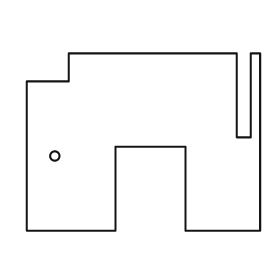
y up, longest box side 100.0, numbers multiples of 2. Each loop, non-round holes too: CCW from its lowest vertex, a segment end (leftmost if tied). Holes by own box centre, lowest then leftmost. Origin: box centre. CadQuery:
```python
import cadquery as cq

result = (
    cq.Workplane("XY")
    .moveTo(-50.0, -38.0)
    .lineTo(-12.0, -38.0)
    .lineTo(-12.0, -2.0)
    .lineTo(18.0, -2.0)
    .lineTo(18.0, -38.0)
    .lineTo(50.0, -38.0)
    .lineTo(50.0, 38.0)
    .lineTo(46.0, 38.0)
    .lineTo(46.0, 2.0)
    .lineTo(40.0, 2.0)
    .lineTo(40.0, 38.0)
    .lineTo(-32.0, 38.0)
    .lineTo(-32.0, 26.0)
    .lineTo(-50.0, 26.0)
    .close()
    .moveTo(-38.0, -6.0)
    .circle(2.0)
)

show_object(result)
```